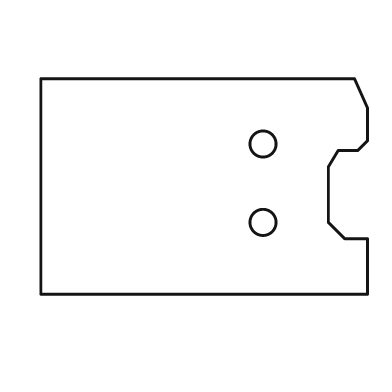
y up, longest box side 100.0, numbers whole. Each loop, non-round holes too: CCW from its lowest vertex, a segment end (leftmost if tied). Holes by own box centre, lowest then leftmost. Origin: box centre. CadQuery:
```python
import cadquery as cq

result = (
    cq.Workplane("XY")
    .moveTo(-50.0, -33.0)
    .lineTo(50.0, -33.0)
    .lineTo(50.0, -16.0)
    .lineTo(43.0, -16.0)
    .lineTo(38.0, -11.0)
    .lineTo(38.0, 6.0)
    .lineTo(41.0, 11.0)
    .lineTo(47.0, 11.0)
    .lineTo(50.0, 14.0)
    .lineTo(50.0, 24.0)
    .lineTo(46.0, 33.0)
    .lineTo(-50.0, 33.0)
    .close()
    .moveTo(18.0, -11.0)
    .circle(4.0)
    .moveTo(18.0, 13.0)
    .circle(4.0)
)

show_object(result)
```